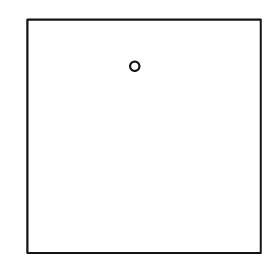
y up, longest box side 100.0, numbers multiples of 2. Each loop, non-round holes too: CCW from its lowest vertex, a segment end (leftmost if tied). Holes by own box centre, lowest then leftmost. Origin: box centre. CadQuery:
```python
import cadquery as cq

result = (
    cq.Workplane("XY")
    .moveTo(-50.0, -50.0)
    .lineTo(50.0, -50.0)
    .lineTo(50.0, 50.0)
    .lineTo(-50.0, 50.0)
    .close()
    .moveTo(-4.0, 30.0)
    .circle(2.0)
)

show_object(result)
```